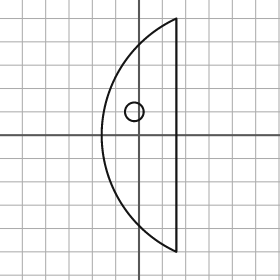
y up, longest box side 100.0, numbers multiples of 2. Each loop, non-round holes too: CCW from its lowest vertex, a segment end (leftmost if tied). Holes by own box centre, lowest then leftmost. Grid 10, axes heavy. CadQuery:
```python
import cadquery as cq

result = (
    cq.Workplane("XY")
    .moveTo(16.0, -50.0)
    .lineTo(16.0, 50.0)
    .threePointArc((-16.0, 0.0), (16.0, -50.0))
    .close()
    .moveTo(-2.0, 10.0)
    .circle(4.0)
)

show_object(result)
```